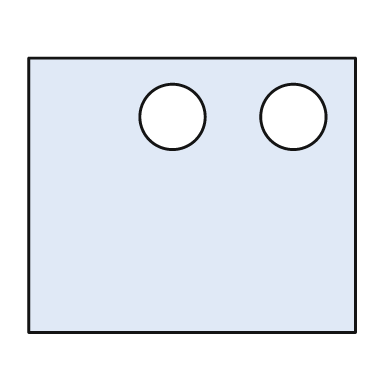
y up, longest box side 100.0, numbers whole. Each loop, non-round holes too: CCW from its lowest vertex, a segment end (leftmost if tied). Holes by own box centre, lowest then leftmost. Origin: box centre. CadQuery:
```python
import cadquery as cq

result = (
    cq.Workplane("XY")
    .moveTo(-50.0, -42.0)
    .lineTo(50.0, -42.0)
    .lineTo(50.0, 42.0)
    .lineTo(-50.0, 42.0)
    .close()
    .moveTo(-6.0, 24.0)
    .circle(10.0)
    .moveTo(31.0, 24.0)
    .circle(10.0)
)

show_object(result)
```